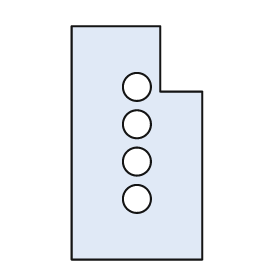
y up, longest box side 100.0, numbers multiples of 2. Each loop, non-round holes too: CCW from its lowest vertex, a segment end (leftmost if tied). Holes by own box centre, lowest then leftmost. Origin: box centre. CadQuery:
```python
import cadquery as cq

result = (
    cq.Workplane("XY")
    .moveTo(-28.0, -50.0)
    .lineTo(28.0, -50.0)
    .lineTo(28.0, 22.0)
    .lineTo(10.0, 22.0)
    .lineTo(10.0, 50.0)
    .lineTo(-28.0, 50.0)
    .close()
    .moveTo(0.0, -24.0)
    .circle(6.0)
    .moveTo(0.0, -8.0)
    .circle(6.0)
    .moveTo(0.0, 8.0)
    .circle(6.0)
    .moveTo(0.0, 24.0)
    .circle(6.0)
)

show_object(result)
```